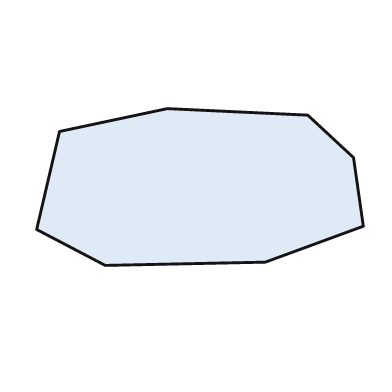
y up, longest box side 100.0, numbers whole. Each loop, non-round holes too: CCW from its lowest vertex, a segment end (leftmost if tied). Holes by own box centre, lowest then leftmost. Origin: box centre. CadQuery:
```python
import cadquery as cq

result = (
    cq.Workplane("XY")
    .moveTo(-29.0, -24.0)
    .lineTo(20.0, -23.0)
    .lineTo(50.0, -12.0)
    .lineTo(47.0, 9.0)
    .lineTo(33.0, 22.0)
    .lineTo(-10.0, 24.0)
    .lineTo(-43.0, 17.0)
    .lineTo(-50.0, -13.0)
    .close()
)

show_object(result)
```